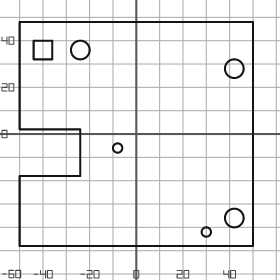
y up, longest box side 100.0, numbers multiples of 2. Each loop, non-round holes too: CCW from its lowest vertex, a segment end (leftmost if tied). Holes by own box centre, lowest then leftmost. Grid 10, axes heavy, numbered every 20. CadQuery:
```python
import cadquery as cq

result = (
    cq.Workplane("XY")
    .moveTo(-50.0, -48.0)
    .lineTo(50.0, -48.0)
    .lineTo(50.0, 48.0)
    .lineTo(-50.0, 48.0)
    .lineTo(-50.0, 2.0)
    .lineTo(-24.0, 2.0)
    .lineTo(-24.0, -18.0)
    .lineTo(-50.0, -18.0)
    .close()
    .moveTo(30.0, -42.0)
    .circle(2.0)
    .moveTo(42.0, -36.0)
    .circle(4.0)
    .moveTo(-8.0, -6.0)
    .circle(2.0)
    .moveTo(42.0, 28.0)
    .circle(4.0)
    .moveTo(-44.0, 32.0)
    .lineTo(-36.0, 32.0)
    .lineTo(-36.0, 40.0)
    .lineTo(-44.0, 40.0)
    .close()
    .moveTo(-24.0, 36.0)
    .circle(4.0)
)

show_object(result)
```